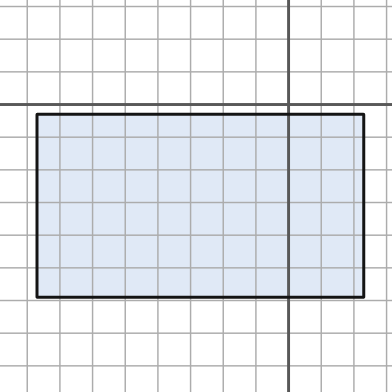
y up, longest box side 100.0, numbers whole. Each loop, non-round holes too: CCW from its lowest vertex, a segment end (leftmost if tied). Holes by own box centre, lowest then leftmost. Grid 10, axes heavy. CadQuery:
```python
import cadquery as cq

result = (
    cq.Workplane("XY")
    .moveTo(-77.0, -59.0)
    .lineTo(23.0, -59.0)
    .lineTo(23.0, -3.0)
    .lineTo(-77.0, -3.0)
    .close()
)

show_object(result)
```